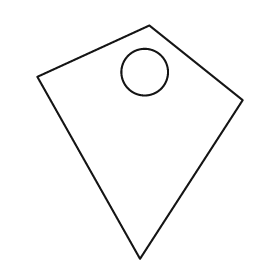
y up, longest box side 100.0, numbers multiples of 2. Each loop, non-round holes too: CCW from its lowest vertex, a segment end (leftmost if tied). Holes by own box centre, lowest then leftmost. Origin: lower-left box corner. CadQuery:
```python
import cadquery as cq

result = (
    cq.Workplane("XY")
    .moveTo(44.0, 0.0)
    .lineTo(88.0, 68.0)
    .lineTo(48.0, 100.0)
    .lineTo(0.0, 78.0)
    .close()
    .moveTo(46.0, 80.0)
    .circle(10.0)
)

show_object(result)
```